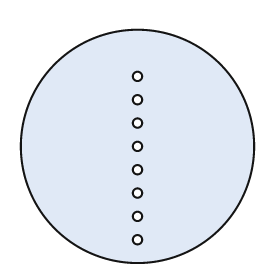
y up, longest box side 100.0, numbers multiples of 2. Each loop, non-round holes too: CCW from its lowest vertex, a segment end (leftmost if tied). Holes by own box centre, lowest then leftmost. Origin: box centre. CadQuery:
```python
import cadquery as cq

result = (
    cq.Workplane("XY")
    .moveTo(0.0, 0.0)
    .circle(50.0)
    .moveTo(0.0, -40.0)
    .circle(2.0)
    .moveTo(0.0, -30.0)
    .circle(2.0)
    .moveTo(0.0, -20.0)
    .circle(2.0)
    .moveTo(0.0, -10.0)
    .circle(2.0)
    .moveTo(0.0, 0.0)
    .circle(2.0)
    .moveTo(0.0, 10.0)
    .circle(2.0)
    .moveTo(0.0, 20.0)
    .circle(2.0)
    .moveTo(0.0, 30.0)
    .circle(2.0)
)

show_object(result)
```